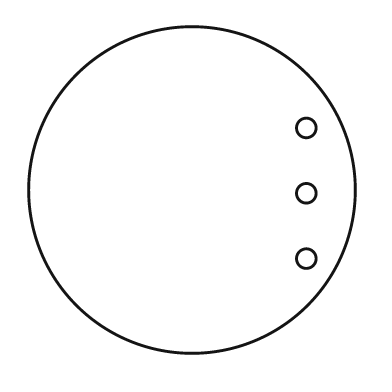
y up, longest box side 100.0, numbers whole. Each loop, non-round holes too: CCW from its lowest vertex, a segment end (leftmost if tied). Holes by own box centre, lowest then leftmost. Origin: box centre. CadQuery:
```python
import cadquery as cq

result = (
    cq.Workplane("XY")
    .moveTo(0.0, 0.0)
    .circle(50.0)
    .moveTo(35.0, -21.0)
    .circle(3.0)
    .moveTo(35.0, -1.0)
    .circle(3.0)
    .moveTo(35.0, 19.0)
    .circle(3.0)
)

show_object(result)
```